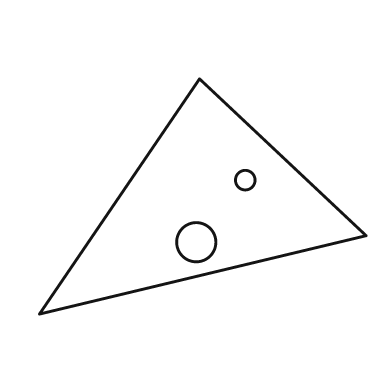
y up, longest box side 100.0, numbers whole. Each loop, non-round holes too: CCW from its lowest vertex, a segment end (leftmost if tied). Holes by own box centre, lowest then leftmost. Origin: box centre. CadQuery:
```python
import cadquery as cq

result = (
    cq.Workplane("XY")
    .moveTo(-50.0, -36.0)
    .lineTo(50.0, -12.0)
    .lineTo(-1.0, 36.0)
    .close()
    .moveTo(-2.0, -14.0)
    .circle(6.0)
    .moveTo(13.0, 5.0)
    .circle(3.0)
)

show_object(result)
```